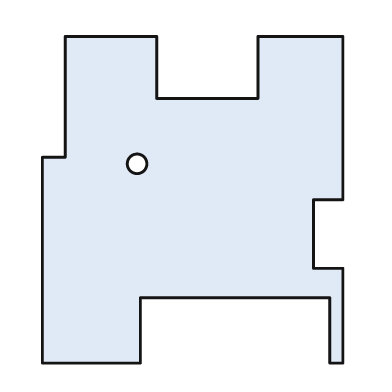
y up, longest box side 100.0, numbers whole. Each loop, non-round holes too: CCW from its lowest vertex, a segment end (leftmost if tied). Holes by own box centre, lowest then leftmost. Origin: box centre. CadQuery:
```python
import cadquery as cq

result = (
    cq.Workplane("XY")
    .moveTo(-46.0, -50.0)
    .lineTo(-16.0, -50.0)
    .lineTo(-16.0, -30.0)
    .lineTo(42.0, -30.0)
    .lineTo(42.0, -50.0)
    .lineTo(46.0, -50.0)
    .lineTo(46.0, -21.0)
    .lineTo(37.0, -21.0)
    .lineTo(37.0, 0.0)
    .lineTo(46.0, 0.0)
    .lineTo(46.0, 50.0)
    .lineTo(20.0, 50.0)
    .lineTo(20.0, 31.0)
    .lineTo(-11.0, 31.0)
    .lineTo(-11.0, 50.0)
    .lineTo(-39.0, 50.0)
    .lineTo(-39.0, 13.0)
    .lineTo(-46.0, 13.0)
    .close()
    .moveTo(-17.0, 11.0)
    .circle(3.0)
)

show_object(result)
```